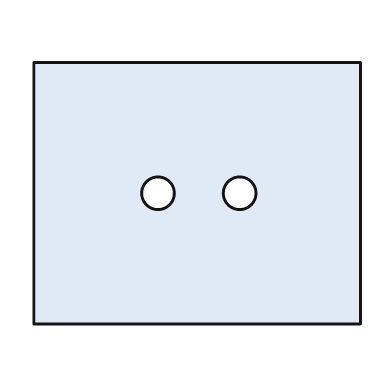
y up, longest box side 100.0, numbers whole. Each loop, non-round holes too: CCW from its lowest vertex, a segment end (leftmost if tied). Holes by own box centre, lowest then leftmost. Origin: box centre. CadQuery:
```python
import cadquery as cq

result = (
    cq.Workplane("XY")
    .moveTo(-50.0, -40.0)
    .lineTo(50.0, -40.0)
    .lineTo(50.0, 40.0)
    .lineTo(-50.0, 40.0)
    .close()
    .moveTo(-12.0, 0.0)
    .circle(5.0)
    .moveTo(13.0, 0.0)
    .circle(5.0)
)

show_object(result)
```